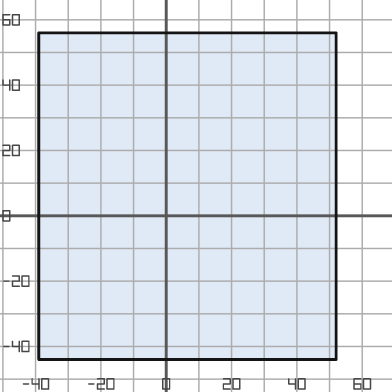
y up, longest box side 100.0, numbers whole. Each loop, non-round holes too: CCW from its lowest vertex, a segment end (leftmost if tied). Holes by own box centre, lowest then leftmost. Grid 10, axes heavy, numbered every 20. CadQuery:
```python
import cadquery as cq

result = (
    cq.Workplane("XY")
    .moveTo(-39.0, -44.0)
    .lineTo(52.0, -44.0)
    .lineTo(52.0, 56.0)
    .lineTo(-39.0, 56.0)
    .close()
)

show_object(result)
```